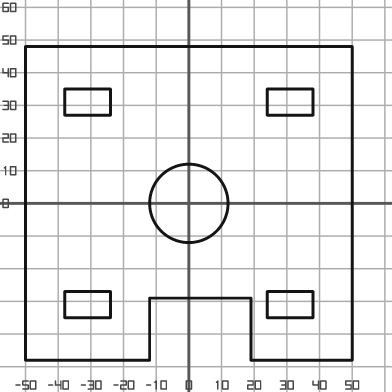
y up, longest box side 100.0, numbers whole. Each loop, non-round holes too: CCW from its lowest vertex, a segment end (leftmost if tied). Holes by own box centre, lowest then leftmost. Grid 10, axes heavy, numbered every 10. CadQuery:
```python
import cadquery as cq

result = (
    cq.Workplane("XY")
    .moveTo(-50.0, -48.0)
    .lineTo(-12.0, -48.0)
    .lineTo(-12.0, -29.0)
    .lineTo(19.0, -29.0)
    .lineTo(19.0, -48.0)
    .lineTo(50.0, -48.0)
    .lineTo(50.0, 48.0)
    .lineTo(-50.0, 48.0)
    .close()
    .moveTo(-38.0, -35.0)
    .lineTo(-24.0, -35.0)
    .lineTo(-24.0, -27.0)
    .lineTo(-38.0, -27.0)
    .close()
    .moveTo(24.0, -35.0)
    .lineTo(38.0, -35.0)
    .lineTo(38.0, -27.0)
    .lineTo(24.0, -27.0)
    .close()
    .moveTo(0.0, 0.0)
    .circle(12.0)
    .moveTo(-38.0, 27.0)
    .lineTo(-24.0, 27.0)
    .lineTo(-24.0, 35.0)
    .lineTo(-38.0, 35.0)
    .close()
    .moveTo(24.0, 27.0)
    .lineTo(38.0, 27.0)
    .lineTo(38.0, 35.0)
    .lineTo(24.0, 35.0)
    .close()
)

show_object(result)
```